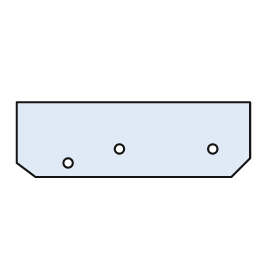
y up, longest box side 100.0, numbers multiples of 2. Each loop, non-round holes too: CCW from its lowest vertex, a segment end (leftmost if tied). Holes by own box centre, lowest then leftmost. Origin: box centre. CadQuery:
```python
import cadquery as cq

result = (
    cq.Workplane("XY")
    .moveTo(-42.0, -16.0)
    .lineTo(42.0, -16.0)
    .lineTo(50.0, -8.0)
    .lineTo(50.0, 16.0)
    .lineTo(-50.0, 16.0)
    .lineTo(-50.0, -10.0)
    .close()
    .moveTo(-28.0, -10.0)
    .circle(2.0)
    .moveTo(-6.0, -4.0)
    .circle(2.0)
    .moveTo(34.0, -4.0)
    .circle(2.0)
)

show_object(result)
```